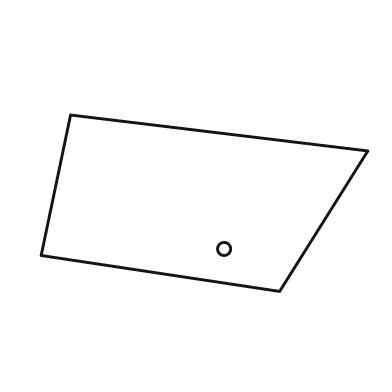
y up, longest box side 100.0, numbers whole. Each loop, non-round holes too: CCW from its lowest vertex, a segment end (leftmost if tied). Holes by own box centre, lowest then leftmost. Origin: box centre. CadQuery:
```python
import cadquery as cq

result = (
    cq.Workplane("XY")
    .moveTo(23.0, -27.0)
    .lineTo(50.0, 16.0)
    .lineTo(-41.0, 27.0)
    .lineTo(-50.0, -16.0)
    .close()
    .moveTo(6.0, -14.0)
    .circle(2.0)
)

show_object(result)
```